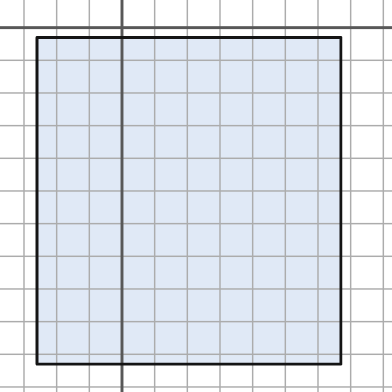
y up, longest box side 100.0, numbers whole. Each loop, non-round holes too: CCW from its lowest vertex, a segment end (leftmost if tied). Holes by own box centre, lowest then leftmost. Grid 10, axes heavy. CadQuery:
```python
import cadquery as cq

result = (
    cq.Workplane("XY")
    .moveTo(-26.0, -103.0)
    .lineTo(67.0, -103.0)
    .lineTo(67.0, -3.0)
    .lineTo(-26.0, -3.0)
    .close()
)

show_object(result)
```